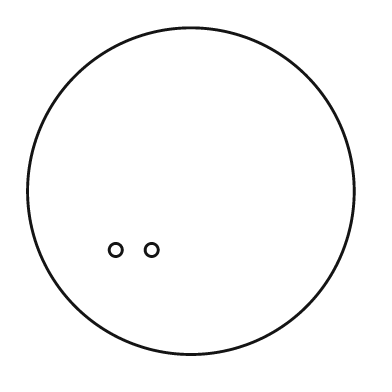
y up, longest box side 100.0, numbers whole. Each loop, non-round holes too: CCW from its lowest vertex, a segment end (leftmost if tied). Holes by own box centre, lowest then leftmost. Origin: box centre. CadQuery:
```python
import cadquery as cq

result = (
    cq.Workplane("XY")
    .moveTo(0.0, 0.0)
    .circle(50.0)
    .moveTo(-23.0, -18.0)
    .circle(2.0)
    .moveTo(-12.0, -18.0)
    .circle(2.0)
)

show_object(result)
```